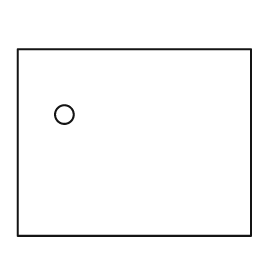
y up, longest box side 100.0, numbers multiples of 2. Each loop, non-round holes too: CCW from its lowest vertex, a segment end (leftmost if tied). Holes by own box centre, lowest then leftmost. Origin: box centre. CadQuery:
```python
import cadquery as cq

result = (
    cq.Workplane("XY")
    .moveTo(-50.0, -40.0)
    .lineTo(50.0, -40.0)
    .lineTo(50.0, 40.0)
    .lineTo(-50.0, 40.0)
    .close()
    .moveTo(-30.0, 12.0)
    .circle(4.0)
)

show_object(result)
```